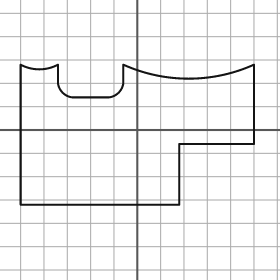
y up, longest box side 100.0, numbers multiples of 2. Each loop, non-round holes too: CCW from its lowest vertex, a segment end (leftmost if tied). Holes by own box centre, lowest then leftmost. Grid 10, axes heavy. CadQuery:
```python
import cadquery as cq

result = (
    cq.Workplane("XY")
    .moveTo(-50.0, -32.0)
    .lineTo(18.0, -32.0)
    .lineTo(18.0, -6.0)
    .lineTo(50.0, -6.0)
    .lineTo(50.0, 28.0)
    .threePointArc((22.0, 22.0), (-6.0, 28.0))
    .lineTo(-6.0, 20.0)
    .threePointArc((-8.0, 16.0), (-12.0, 14.0))
    .lineTo(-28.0, 14.0)
    .threePointArc((-32.0, 16.0), (-34.0, 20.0))
    .lineTo(-34.0, 28.0)
    .threePointArc((-42.0, 26.0), (-50.0, 28.0))
    .close()
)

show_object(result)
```